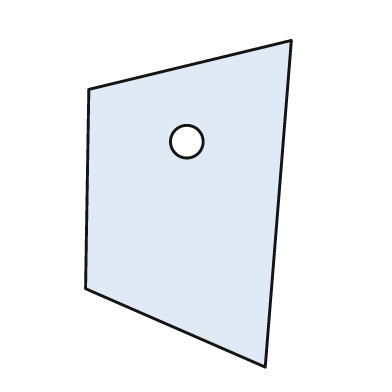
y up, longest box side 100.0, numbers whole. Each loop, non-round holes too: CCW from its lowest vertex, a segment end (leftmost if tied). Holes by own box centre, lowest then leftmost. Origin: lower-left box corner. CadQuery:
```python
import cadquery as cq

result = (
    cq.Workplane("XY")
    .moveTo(55.0, 0.0)
    .lineTo(63.0, 100.0)
    .lineTo(1.0, 85.0)
    .lineTo(0.0, 24.0)
    .close()
    .moveTo(31.0, 69.0)
    .circle(5.0)
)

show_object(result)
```